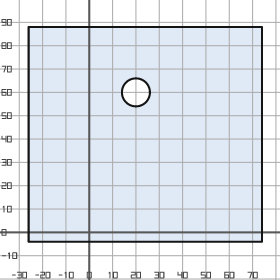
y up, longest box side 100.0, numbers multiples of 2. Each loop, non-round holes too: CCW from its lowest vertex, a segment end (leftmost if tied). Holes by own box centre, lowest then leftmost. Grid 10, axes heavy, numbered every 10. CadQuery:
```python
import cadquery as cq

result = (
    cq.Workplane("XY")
    .moveTo(-26.0, -4.0)
    .lineTo(74.0, -4.0)
    .lineTo(74.0, 88.0)
    .lineTo(-26.0, 88.0)
    .close()
    .moveTo(20.0, 60.0)
    .circle(6.0)
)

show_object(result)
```